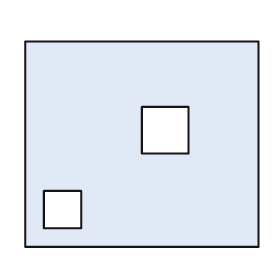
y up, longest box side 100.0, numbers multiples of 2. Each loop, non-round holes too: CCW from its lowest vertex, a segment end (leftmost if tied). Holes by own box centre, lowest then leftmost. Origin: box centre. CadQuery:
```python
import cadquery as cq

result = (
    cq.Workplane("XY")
    .moveTo(-50.0, -44.0)
    .lineTo(50.0, -44.0)
    .lineTo(50.0, 44.0)
    .lineTo(-50.0, 44.0)
    .close()
    .moveTo(-42.0, -36.0)
    .lineTo(-26.0, -36.0)
    .lineTo(-26.0, -20.0)
    .lineTo(-42.0, -20.0)
    .close()
    .moveTo(0.0, -4.0)
    .lineTo(20.0, -4.0)
    .lineTo(20.0, 16.0)
    .lineTo(0.0, 16.0)
    .close()
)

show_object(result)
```